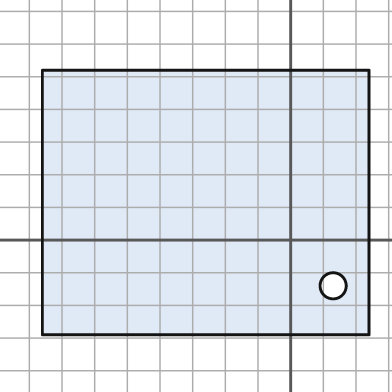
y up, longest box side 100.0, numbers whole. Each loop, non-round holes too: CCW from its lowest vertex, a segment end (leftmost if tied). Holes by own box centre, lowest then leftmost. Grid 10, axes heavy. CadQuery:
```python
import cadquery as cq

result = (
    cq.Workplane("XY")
    .moveTo(-76.0, -29.0)
    .lineTo(24.0, -29.0)
    .lineTo(24.0, 52.0)
    .lineTo(-76.0, 52.0)
    .close()
    .moveTo(13.0, -14.0)
    .circle(4.0)
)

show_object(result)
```